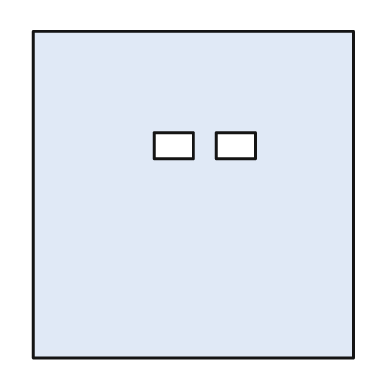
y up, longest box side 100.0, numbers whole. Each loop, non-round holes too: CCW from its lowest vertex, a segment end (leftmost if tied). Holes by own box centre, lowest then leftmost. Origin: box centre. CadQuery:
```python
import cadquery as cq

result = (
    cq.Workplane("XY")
    .moveTo(-49.0, -50.0)
    .lineTo(49.0, -50.0)
    .lineTo(49.0, 50.0)
    .lineTo(-49.0, 50.0)
    .close()
    .moveTo(-12.0, 11.0)
    .lineTo(0.0, 11.0)
    .lineTo(0.0, 19.0)
    .lineTo(-12.0, 19.0)
    .close()
    .moveTo(7.0, 11.0)
    .lineTo(19.0, 11.0)
    .lineTo(19.0, 19.0)
    .lineTo(7.0, 19.0)
    .close()
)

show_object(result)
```